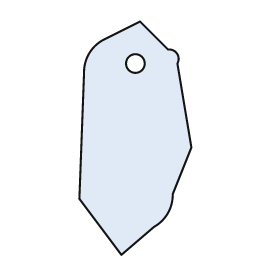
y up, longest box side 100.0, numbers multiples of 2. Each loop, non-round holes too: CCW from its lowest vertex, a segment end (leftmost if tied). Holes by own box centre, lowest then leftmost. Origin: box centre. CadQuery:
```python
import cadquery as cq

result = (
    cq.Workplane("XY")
    .moveTo(-6.0, -50.0)
    .lineTo(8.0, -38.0)
    .threePointArc((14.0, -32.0), (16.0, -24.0))
    .lineTo(24.0, -4.0)
    .lineTo(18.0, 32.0)
    .threePointArc((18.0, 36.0), (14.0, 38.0))
    .lineTo(2.0, 50.0)
    .lineTo(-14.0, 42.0)
    .threePointArc((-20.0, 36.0), (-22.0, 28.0))
    .lineTo(-24.0, -26.0)
    .close()
    .moveTo(0.0, 32.0)
    .circle(4.0)
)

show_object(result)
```